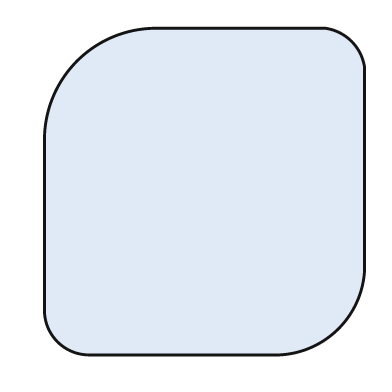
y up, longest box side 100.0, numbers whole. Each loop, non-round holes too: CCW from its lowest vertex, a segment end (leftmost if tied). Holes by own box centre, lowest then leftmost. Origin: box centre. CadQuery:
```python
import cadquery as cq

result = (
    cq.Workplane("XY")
    .moveTo(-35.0, -50.0)
    .lineTo(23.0, -50.0)
    .threePointArc((41.0, -42.0), (49.0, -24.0))
    .lineTo(49.0, 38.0)
    .threePointArc((45.0, 46.0), (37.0, 50.0))
    .lineTo(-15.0, 50.0)
    .threePointArc((-39.0, 40.0), (-49.0, 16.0))
    .lineTo(-49.0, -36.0)
    .threePointArc((-45.0, -46.0), (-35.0, -50.0))
    .close()
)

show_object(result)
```